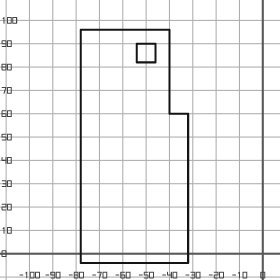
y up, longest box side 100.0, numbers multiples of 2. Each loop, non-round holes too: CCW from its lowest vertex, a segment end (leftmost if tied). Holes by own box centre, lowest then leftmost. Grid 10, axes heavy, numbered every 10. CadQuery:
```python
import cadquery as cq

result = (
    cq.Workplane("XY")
    .moveTo(-78.0, -4.0)
    .lineTo(-32.0, -4.0)
    .lineTo(-32.0, 60.0)
    .lineTo(-40.0, 60.0)
    .lineTo(-40.0, 96.0)
    .lineTo(-78.0, 96.0)
    .close()
    .moveTo(-54.0, 82.0)
    .lineTo(-46.0, 82.0)
    .lineTo(-46.0, 90.0)
    .lineTo(-54.0, 90.0)
    .close()
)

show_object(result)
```